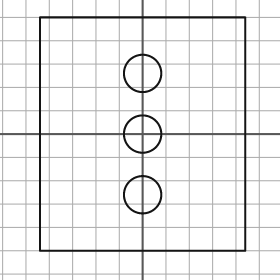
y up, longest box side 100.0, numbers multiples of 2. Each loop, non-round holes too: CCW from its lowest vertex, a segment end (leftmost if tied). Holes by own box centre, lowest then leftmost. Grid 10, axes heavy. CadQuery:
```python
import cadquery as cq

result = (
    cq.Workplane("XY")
    .moveTo(-44.0, -50.0)
    .lineTo(44.0, -50.0)
    .lineTo(44.0, 50.0)
    .lineTo(-44.0, 50.0)
    .close()
    .moveTo(0.0, -26.0)
    .circle(8.0)
    .moveTo(0.0, 0.0)
    .circle(8.0)
    .moveTo(0.0, 26.0)
    .circle(8.0)
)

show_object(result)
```